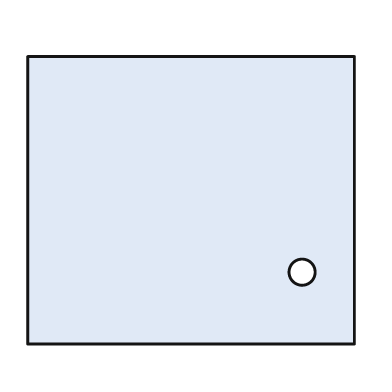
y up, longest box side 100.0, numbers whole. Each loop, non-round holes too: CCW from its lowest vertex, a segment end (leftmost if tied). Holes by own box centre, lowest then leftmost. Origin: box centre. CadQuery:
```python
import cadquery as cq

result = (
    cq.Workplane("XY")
    .moveTo(-50.0, -44.0)
    .lineTo(50.0, -44.0)
    .lineTo(50.0, 44.0)
    .lineTo(-50.0, 44.0)
    .close()
    .moveTo(34.0, -22.0)
    .circle(4.0)
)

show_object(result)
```